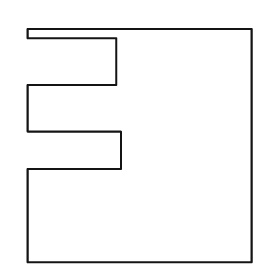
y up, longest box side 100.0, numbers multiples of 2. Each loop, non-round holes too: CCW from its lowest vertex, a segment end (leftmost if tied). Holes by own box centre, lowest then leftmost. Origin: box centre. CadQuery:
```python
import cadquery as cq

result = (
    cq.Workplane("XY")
    .moveTo(-48.0, -50.0)
    .lineTo(48.0, -50.0)
    .lineTo(48.0, 50.0)
    .lineTo(-48.0, 50.0)
    .lineTo(-48.0, 46.0)
    .lineTo(-10.0, 46.0)
    .lineTo(-10.0, 26.0)
    .lineTo(-48.0, 26.0)
    .lineTo(-48.0, 6.0)
    .lineTo(-8.0, 6.0)
    .lineTo(-8.0, -10.0)
    .lineTo(-48.0, -10.0)
    .close()
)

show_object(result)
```